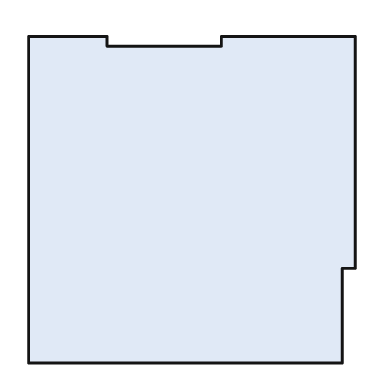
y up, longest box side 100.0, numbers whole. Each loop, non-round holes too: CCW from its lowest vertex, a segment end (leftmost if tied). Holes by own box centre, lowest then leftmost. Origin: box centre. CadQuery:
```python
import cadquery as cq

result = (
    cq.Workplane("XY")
    .moveTo(-50.0, -50.0)
    .lineTo(46.0, -50.0)
    .lineTo(46.0, -21.0)
    .lineTo(50.0, -21.0)
    .lineTo(50.0, 50.0)
    .lineTo(9.0, 50.0)
    .lineTo(9.0, 47.0)
    .lineTo(-26.0, 47.0)
    .lineTo(-26.0, 50.0)
    .lineTo(-50.0, 50.0)
    .close()
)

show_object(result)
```